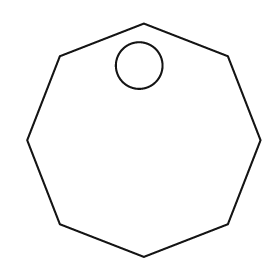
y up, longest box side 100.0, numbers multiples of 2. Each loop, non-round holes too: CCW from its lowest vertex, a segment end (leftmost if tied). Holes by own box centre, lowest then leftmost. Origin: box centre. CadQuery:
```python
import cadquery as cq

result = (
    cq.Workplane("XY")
    .moveTo(0.0, -50.0)
    .lineTo(36.0, -36.0)
    .lineTo(50.0, 0.0)
    .lineTo(36.0, 36.0)
    .lineTo(0.0, 50.0)
    .lineTo(-36.0, 36.0)
    .lineTo(-50.0, 0.0)
    .lineTo(-36.0, -36.0)
    .close()
    .moveTo(-2.0, 32.0)
    .circle(10.0)
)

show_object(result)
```